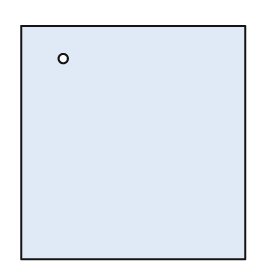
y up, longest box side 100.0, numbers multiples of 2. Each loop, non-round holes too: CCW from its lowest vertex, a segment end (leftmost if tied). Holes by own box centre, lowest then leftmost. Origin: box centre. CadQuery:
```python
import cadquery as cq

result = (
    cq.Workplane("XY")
    .moveTo(-48.0, -50.0)
    .lineTo(48.0, -50.0)
    .lineTo(48.0, 50.0)
    .lineTo(-48.0, 50.0)
    .close()
    .moveTo(-30.0, 36.0)
    .circle(2.0)
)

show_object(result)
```